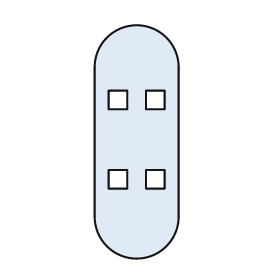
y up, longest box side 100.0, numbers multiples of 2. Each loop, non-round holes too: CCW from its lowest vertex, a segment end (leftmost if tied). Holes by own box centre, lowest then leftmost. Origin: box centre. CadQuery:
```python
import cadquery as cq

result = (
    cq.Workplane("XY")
    .moveTo(-18.0, -32.0)
    .threePointArc((0.0, -50.0), (18.0, -32.0))
    .lineTo(18.0, 32.0)
    .threePointArc((0.0, 50.0), (-18.0, 32.0))
    .close()
    .moveTo(-12.0, -20.0)
    .lineTo(-4.0, -20.0)
    .lineTo(-4.0, -12.0)
    .lineTo(-12.0, -12.0)
    .close()
    .moveTo(4.0, -20.0)
    .lineTo(12.0, -20.0)
    .lineTo(12.0, -12.0)
    .lineTo(4.0, -12.0)
    .close()
    .moveTo(-12.0, 14.0)
    .lineTo(-4.0, 14.0)
    .lineTo(-4.0, 22.0)
    .lineTo(-12.0, 22.0)
    .close()
    .moveTo(4.0, 14.0)
    .lineTo(12.0, 14.0)
    .lineTo(12.0, 22.0)
    .lineTo(4.0, 22.0)
    .close()
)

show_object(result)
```